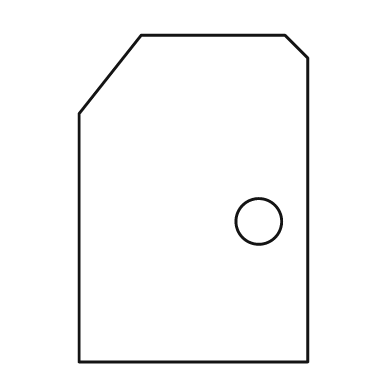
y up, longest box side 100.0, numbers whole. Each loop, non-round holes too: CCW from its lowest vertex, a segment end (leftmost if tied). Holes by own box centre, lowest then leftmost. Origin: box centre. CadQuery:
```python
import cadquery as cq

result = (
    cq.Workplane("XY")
    .moveTo(-35.0, -50.0)
    .lineTo(35.0, -50.0)
    .lineTo(35.0, 43.0)
    .lineTo(28.0, 50.0)
    .lineTo(-16.0, 50.0)
    .lineTo(-35.0, 26.0)
    .close()
    .moveTo(20.0, -7.0)
    .circle(7.0)
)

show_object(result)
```